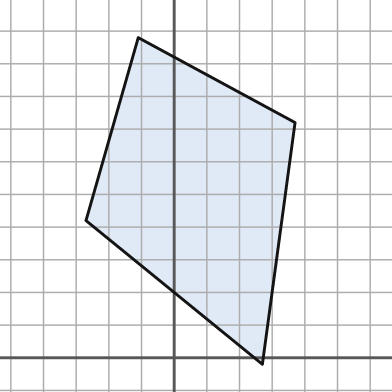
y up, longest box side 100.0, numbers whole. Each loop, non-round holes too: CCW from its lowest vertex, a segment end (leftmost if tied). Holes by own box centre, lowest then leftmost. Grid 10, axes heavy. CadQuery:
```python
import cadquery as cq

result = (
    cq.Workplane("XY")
    .moveTo(27.0, -2.0)
    .lineTo(37.0, 72.0)
    .lineTo(-11.0, 98.0)
    .lineTo(-27.0, 42.0)
    .close()
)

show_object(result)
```